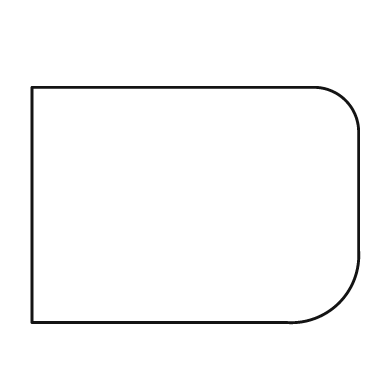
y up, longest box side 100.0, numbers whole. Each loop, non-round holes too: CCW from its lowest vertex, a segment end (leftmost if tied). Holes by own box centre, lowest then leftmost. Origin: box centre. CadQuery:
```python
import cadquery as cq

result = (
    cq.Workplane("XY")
    .moveTo(-50.0, -36.0)
    .lineTo(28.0, -36.0)
    .threePointArc((44.0, -30.0), (50.0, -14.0))
    .lineTo(50.0, 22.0)
    .threePointArc((46.0, 32.0), (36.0, 36.0))
    .lineTo(-50.0, 36.0)
    .close()
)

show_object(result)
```